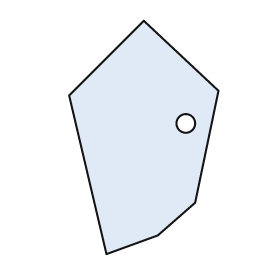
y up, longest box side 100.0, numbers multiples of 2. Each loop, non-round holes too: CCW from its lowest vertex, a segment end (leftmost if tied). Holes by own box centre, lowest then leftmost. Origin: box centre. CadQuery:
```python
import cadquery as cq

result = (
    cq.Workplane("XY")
    .moveTo(-16.0, -50.0)
    .lineTo(6.0, -42.0)
    .lineTo(22.0, -28.0)
    .lineTo(32.0, 20.0)
    .lineTo(0.0, 50.0)
    .lineTo(-32.0, 18.0)
    .close()
    .moveTo(18.0, 6.0)
    .circle(4.0)
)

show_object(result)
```